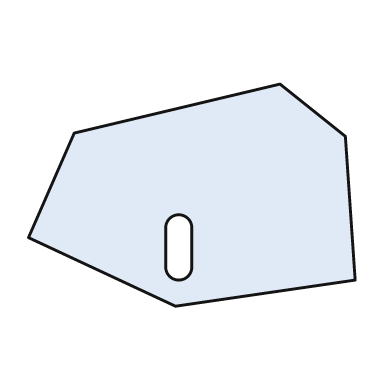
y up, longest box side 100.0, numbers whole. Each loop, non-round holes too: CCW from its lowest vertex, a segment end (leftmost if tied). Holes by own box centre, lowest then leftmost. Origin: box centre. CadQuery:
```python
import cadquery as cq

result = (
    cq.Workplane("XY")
    .moveTo(-5.0, -34.0)
    .lineTo(50.0, -26.0)
    .lineTo(47.0, 18.0)
    .lineTo(27.0, 34.0)
    .lineTo(-36.0, 19.0)
    .lineTo(-50.0, -13.0)
    .close()
    .moveTo(-8.0, -22.0)
    .threePointArc((-4.0, -26.0), (0.0, -22.0))
    .lineTo(0.0, -10.0)
    .threePointArc((-4.0, -6.0), (-8.0, -10.0))
    .close()
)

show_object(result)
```